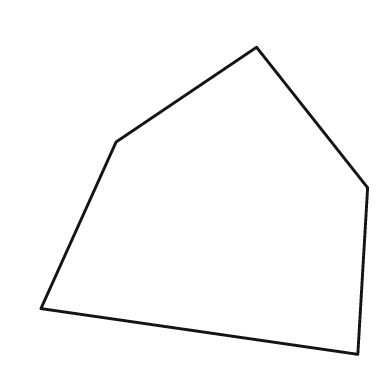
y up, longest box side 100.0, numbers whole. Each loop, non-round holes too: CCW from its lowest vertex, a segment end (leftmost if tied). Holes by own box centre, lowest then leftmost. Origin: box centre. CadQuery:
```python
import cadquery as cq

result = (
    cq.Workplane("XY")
    .moveTo(47.0, -47.0)
    .lineTo(50.0, 4.0)
    .lineTo(16.0, 47.0)
    .lineTo(-27.0, 18.0)
    .lineTo(-50.0, -33.0)
    .close()
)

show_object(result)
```